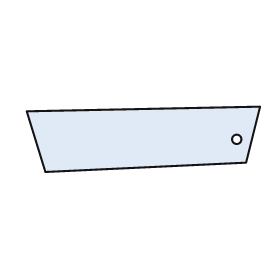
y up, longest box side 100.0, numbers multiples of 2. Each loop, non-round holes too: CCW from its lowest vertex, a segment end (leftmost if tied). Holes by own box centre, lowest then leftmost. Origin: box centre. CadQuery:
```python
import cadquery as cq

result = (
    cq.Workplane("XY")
    .moveTo(-42.0, -14.0)
    .lineTo(44.0, -10.0)
    .lineTo(50.0, 14.0)
    .lineTo(-50.0, 12.0)
    .close()
    .moveTo(40.0, 0.0)
    .circle(2.0)
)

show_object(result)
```